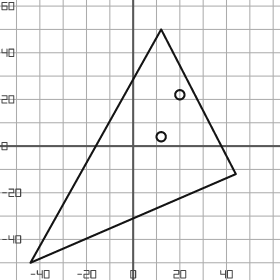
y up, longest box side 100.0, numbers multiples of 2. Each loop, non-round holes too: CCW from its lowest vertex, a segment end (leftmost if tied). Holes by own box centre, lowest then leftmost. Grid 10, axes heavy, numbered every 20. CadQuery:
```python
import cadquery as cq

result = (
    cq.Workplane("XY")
    .moveTo(-44.0, -50.0)
    .lineTo(44.0, -12.0)
    .lineTo(12.0, 50.0)
    .close()
    .moveTo(12.0, 4.0)
    .circle(2.0)
    .moveTo(20.0, 22.0)
    .circle(2.0)
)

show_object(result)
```